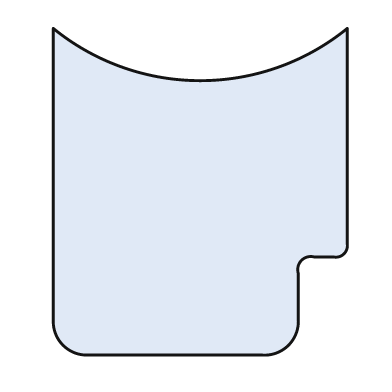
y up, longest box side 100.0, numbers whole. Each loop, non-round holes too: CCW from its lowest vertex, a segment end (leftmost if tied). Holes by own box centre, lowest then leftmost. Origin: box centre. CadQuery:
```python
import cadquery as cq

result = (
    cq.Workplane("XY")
    .moveTo(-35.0, -50.0)
    .lineTo(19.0, -50.0)
    .threePointArc((27.0, -47.0), (30.0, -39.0))
    .lineTo(30.0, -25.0)
    .threePointArc((31.0, -21.0), (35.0, -20.0))
    .lineTo(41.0, -20.0)
    .threePointArc((44.0, -19.0), (45.0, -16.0))
    .lineTo(45.0, 50.0)
    .threePointArc((0.0, 34.0), (-45.0, 50.0))
    .lineTo(-45.0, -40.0)
    .threePointArc((-42.0, -47.0), (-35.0, -50.0))
    .close()
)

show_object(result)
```